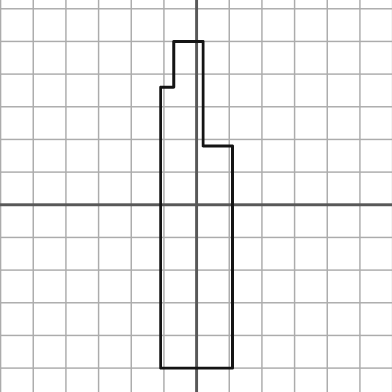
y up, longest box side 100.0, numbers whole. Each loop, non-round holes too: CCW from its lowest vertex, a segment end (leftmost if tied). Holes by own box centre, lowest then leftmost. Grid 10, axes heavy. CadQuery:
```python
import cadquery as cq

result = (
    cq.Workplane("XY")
    .moveTo(-11.0, -50.0)
    .lineTo(11.0, -50.0)
    .lineTo(11.0, 18.0)
    .lineTo(2.0, 18.0)
    .lineTo(2.0, 50.0)
    .lineTo(-7.0, 50.0)
    .lineTo(-7.0, 36.0)
    .lineTo(-11.0, 36.0)
    .close()
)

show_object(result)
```